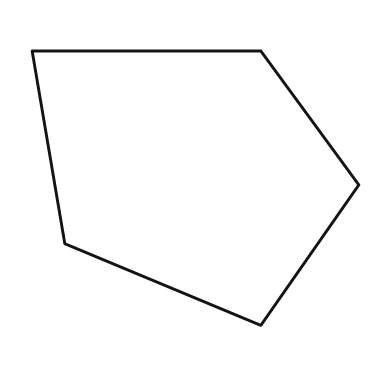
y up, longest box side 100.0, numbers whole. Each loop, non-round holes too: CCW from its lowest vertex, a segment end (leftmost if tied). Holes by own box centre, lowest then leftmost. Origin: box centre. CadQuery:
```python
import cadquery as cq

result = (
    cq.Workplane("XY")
    .moveTo(20.0, -42.0)
    .lineTo(50.0, 1.0)
    .lineTo(20.0, 42.0)
    .lineTo(-50.0, 42.0)
    .lineTo(-40.0, -17.0)
    .close()
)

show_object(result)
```